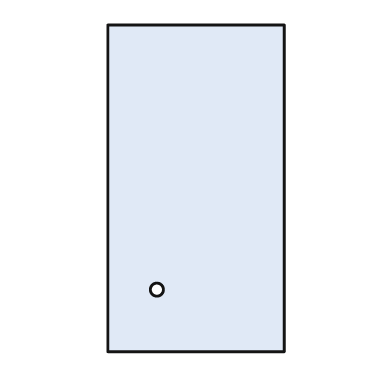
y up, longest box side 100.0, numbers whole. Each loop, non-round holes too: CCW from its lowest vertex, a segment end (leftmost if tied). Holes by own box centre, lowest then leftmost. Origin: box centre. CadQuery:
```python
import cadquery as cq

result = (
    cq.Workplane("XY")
    .moveTo(-27.0, -50.0)
    .lineTo(27.0, -50.0)
    .lineTo(27.0, 50.0)
    .lineTo(-27.0, 50.0)
    .close()
    .moveTo(-12.0, -31.0)
    .circle(2.0)
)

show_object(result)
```